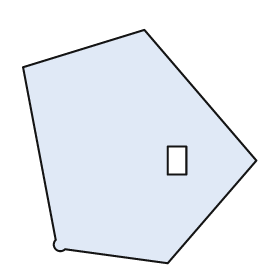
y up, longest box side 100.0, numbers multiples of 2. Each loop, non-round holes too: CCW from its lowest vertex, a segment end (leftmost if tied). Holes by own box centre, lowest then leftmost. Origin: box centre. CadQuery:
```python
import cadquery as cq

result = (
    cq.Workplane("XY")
    .moveTo(12.0, -50.0)
    .lineTo(50.0, -6.0)
    .lineTo(2.0, 50.0)
    .lineTo(-50.0, 34.0)
    .lineTo(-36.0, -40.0)
    .threePointArc((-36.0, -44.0), (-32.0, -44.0))
    .close()
    .moveTo(12.0, -12.0)
    .lineTo(20.0, -12.0)
    .lineTo(20.0, 0.0)
    .lineTo(12.0, 0.0)
    .close()
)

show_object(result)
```